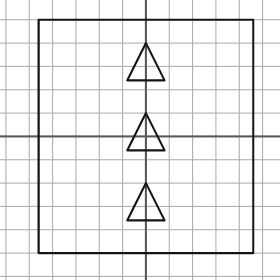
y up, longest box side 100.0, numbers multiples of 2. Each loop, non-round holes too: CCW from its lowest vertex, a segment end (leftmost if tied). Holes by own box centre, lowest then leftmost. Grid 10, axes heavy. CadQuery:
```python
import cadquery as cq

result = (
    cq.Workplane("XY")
    .moveTo(-46.0, -50.0)
    .lineTo(46.0, -50.0)
    .lineTo(46.0, 50.0)
    .lineTo(-46.0, 50.0)
    .close()
    .moveTo(-8.0, -36.0)
    .lineTo(8.0, -36.0)
    .lineTo(0.0, -20.0)
    .close()
    .moveTo(-8.0, -6.0)
    .lineTo(8.0, -6.0)
    .lineTo(0.0, 10.0)
    .close()
    .moveTo(-8.0, 24.0)
    .lineTo(8.0, 24.0)
    .lineTo(0.0, 40.0)
    .close()
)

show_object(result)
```